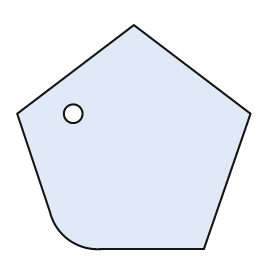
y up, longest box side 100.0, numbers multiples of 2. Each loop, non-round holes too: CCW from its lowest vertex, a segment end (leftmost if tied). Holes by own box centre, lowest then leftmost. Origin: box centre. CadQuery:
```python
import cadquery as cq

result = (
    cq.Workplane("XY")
    .moveTo(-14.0, -48.0)
    .lineTo(30.0, -48.0)
    .lineTo(50.0, 10.0)
    .lineTo(0.0, 48.0)
    .lineTo(-50.0, 10.0)
    .lineTo(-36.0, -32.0)
    .threePointArc((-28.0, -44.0), (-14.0, -48.0))
    .close()
    .moveTo(-26.0, 10.0)
    .circle(4.0)
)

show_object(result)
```